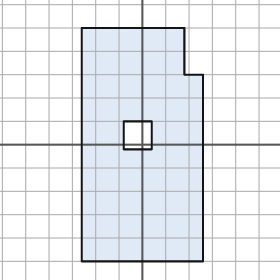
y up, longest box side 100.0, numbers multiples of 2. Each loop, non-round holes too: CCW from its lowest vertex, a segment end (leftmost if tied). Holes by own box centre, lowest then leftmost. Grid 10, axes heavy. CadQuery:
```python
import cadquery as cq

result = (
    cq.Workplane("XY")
    .moveTo(-26.0, -50.0)
    .lineTo(26.0, -50.0)
    .lineTo(26.0, 30.0)
    .lineTo(18.0, 30.0)
    .lineTo(18.0, 50.0)
    .lineTo(-26.0, 50.0)
    .close()
    .moveTo(-8.0, -2.0)
    .lineTo(4.0, -2.0)
    .lineTo(4.0, 10.0)
    .lineTo(-8.0, 10.0)
    .close()
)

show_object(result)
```